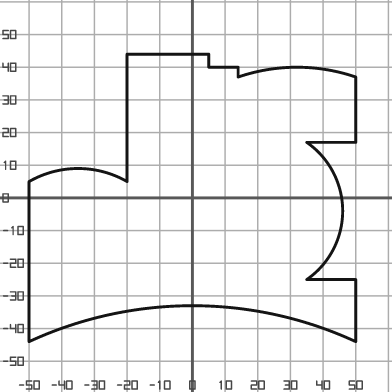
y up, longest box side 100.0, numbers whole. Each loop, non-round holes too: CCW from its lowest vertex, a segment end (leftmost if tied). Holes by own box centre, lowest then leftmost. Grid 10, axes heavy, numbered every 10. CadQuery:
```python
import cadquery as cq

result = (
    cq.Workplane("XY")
    .moveTo(-50.0, -44.0)
    .threePointArc((0.0, -33.0), (50.0, -44.0))
    .lineTo(50.0, -25.0)
    .lineTo(35.0, -25.0)
    .threePointArc((46.0, -4.0), (35.0, 17.0))
    .lineTo(50.0, 17.0)
    .lineTo(50.0, 37.0)
    .threePointArc((32.0, 40.0), (14.0, 37.0))
    .lineTo(14.0, 40.0)
    .lineTo(5.0, 40.0)
    .lineTo(5.0, 44.0)
    .lineTo(-20.0, 44.0)
    .lineTo(-20.0, 5.0)
    .threePointArc((-35.0, 9.0), (-50.0, 5.0))
    .close()
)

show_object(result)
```